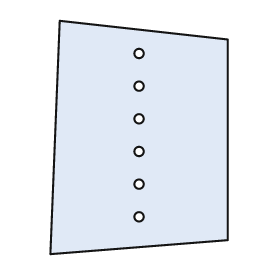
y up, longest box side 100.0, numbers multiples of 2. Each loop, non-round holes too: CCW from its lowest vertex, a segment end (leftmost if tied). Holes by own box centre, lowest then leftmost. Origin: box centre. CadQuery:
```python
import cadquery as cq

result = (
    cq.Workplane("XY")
    .moveTo(-38.0, -50.0)
    .lineTo(38.0, -44.0)
    .lineTo(38.0, 42.0)
    .lineTo(-34.0, 50.0)
    .close()
    .moveTo(0.0, -34.0)
    .circle(2.0)
    .moveTo(0.0, -20.0)
    .circle(2.0)
    .moveTo(0.0, -6.0)
    .circle(2.0)
    .moveTo(0.0, 8.0)
    .circle(2.0)
    .moveTo(0.0, 22.0)
    .circle(2.0)
    .moveTo(0.0, 36.0)
    .circle(2.0)
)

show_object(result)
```